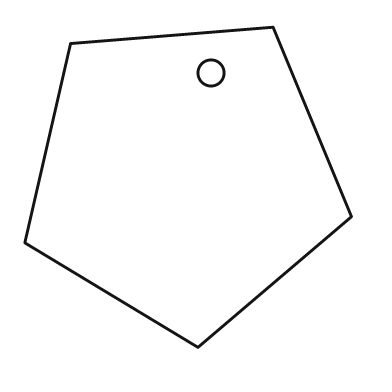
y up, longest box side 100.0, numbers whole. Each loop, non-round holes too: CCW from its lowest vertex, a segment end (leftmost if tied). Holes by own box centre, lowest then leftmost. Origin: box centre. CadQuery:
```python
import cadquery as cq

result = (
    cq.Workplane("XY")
    .moveTo(3.0, -49.0)
    .lineTo(50.0, -9.0)
    .lineTo(26.0, 49.0)
    .lineTo(-36.0, 44.0)
    .lineTo(-50.0, -17.0)
    .close()
    .moveTo(7.0, 35.0)
    .circle(4.0)
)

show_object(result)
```